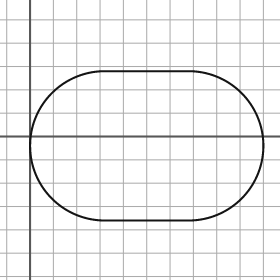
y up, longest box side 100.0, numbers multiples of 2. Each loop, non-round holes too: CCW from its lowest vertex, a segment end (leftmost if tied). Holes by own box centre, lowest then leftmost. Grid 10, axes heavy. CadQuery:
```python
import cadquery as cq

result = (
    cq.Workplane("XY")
    .moveTo(32.0, -36.0)
    .lineTo(68.0, -36.0)
    .threePointArc((100.0, -4.0), (68.0, 28.0))
    .lineTo(32.0, 28.0)
    .threePointArc((0.0, -4.0), (32.0, -36.0))
    .close()
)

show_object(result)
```